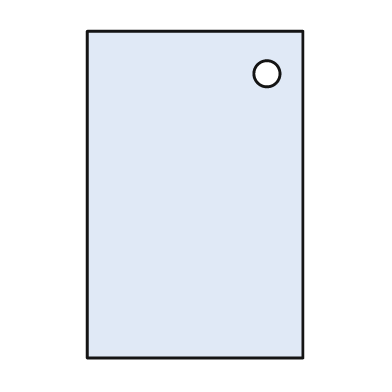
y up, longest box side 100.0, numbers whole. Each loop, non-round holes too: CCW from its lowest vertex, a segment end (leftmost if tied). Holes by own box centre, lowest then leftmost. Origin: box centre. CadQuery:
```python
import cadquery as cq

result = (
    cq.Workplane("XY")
    .moveTo(-33.0, -50.0)
    .lineTo(33.0, -50.0)
    .lineTo(33.0, 50.0)
    .lineTo(-33.0, 50.0)
    .close()
    .moveTo(22.0, 37.0)
    .circle(4.0)
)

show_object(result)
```